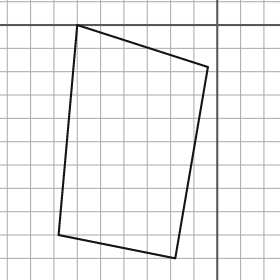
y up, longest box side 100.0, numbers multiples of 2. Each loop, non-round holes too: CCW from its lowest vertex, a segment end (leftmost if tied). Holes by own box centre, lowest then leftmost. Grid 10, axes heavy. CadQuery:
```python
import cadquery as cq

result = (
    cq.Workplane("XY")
    .moveTo(-18.0, -100.0)
    .lineTo(-4.0, -18.0)
    .lineTo(-60.0, 0.0)
    .lineTo(-68.0, -90.0)
    .close()
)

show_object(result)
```